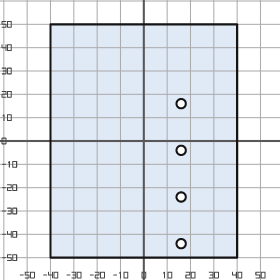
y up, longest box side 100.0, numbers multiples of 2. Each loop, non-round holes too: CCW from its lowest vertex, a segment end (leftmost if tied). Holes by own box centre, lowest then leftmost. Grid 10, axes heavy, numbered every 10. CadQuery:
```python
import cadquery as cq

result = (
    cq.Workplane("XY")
    .moveTo(-40.0, -50.0)
    .lineTo(40.0, -50.0)
    .lineTo(40.0, 50.0)
    .lineTo(-40.0, 50.0)
    .close()
    .moveTo(16.0, -44.0)
    .circle(2.0)
    .moveTo(16.0, -24.0)
    .circle(2.0)
    .moveTo(16.0, -4.0)
    .circle(2.0)
    .moveTo(16.0, 16.0)
    .circle(2.0)
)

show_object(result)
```